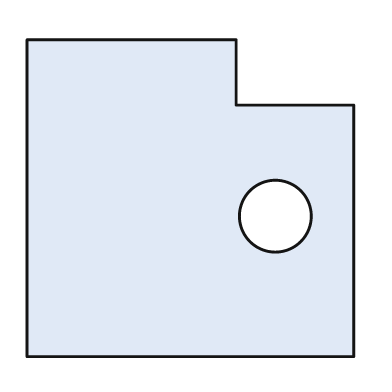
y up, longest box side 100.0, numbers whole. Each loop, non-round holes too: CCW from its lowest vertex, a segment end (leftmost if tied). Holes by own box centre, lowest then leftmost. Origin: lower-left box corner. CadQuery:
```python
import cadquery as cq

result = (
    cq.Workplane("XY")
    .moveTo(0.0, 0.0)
    .lineTo(100.0, 0.0)
    .lineTo(100.0, 77.0)
    .lineTo(64.0, 77.0)
    .lineTo(64.0, 97.0)
    .lineTo(0.0, 97.0)
    .close()
    .moveTo(76.0, 43.0)
    .circle(11.0)
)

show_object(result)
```